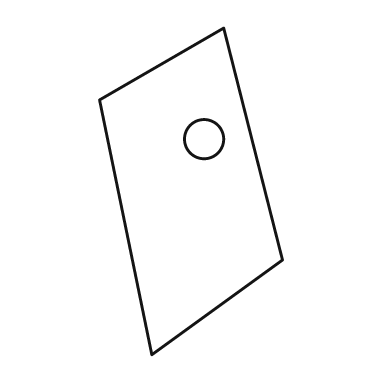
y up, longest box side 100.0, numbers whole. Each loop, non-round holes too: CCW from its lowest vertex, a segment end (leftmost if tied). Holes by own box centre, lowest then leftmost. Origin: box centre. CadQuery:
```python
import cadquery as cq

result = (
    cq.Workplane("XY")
    .moveTo(-12.0, -50.0)
    .lineTo(28.0, -21.0)
    .lineTo(10.0, 50.0)
    .lineTo(-28.0, 28.0)
    .close()
    .moveTo(4.0, 16.0)
    .circle(6.0)
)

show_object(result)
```